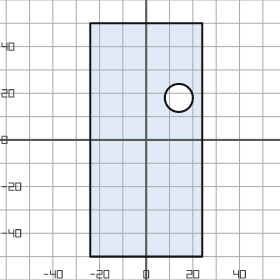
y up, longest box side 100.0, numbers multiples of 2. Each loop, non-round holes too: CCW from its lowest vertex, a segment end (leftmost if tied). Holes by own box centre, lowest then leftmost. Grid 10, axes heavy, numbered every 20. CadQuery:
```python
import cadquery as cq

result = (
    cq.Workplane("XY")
    .moveTo(-24.0, -50.0)
    .lineTo(24.0, -50.0)
    .lineTo(24.0, 50.0)
    .lineTo(-24.0, 50.0)
    .close()
    .moveTo(14.0, 18.0)
    .circle(6.0)
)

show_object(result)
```